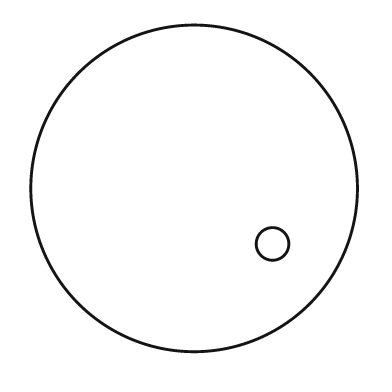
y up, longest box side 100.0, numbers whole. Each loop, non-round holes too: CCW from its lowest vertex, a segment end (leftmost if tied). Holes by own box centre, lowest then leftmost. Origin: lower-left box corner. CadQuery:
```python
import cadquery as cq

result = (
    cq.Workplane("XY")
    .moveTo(50.0, 50.0)
    .circle(50.0)
    .moveTo(74.0, 33.0)
    .circle(5.0)
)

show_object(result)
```